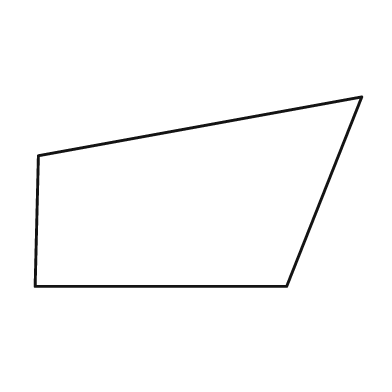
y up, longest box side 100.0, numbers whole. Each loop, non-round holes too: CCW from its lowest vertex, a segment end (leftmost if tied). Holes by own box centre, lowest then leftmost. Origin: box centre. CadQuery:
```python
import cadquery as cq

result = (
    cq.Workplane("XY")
    .moveTo(-50.0, -29.0)
    .lineTo(27.0, -29.0)
    .lineTo(50.0, 29.0)
    .lineTo(-49.0, 11.0)
    .close()
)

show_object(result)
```